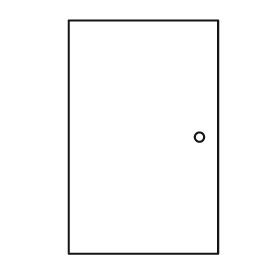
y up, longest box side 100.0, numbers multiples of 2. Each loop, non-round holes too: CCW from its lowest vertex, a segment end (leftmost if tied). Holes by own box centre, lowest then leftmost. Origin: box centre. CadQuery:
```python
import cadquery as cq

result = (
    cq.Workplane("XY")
    .moveTo(-32.0, -50.0)
    .lineTo(32.0, -50.0)
    .lineTo(32.0, 50.0)
    .lineTo(-32.0, 50.0)
    .close()
    .moveTo(24.0, 0.0)
    .circle(2.0)
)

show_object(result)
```